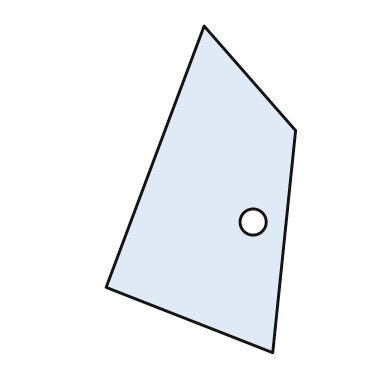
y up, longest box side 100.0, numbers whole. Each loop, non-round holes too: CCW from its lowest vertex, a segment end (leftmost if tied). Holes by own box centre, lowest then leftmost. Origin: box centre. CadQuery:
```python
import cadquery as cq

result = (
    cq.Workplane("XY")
    .moveTo(22.0, -50.0)
    .lineTo(29.0, 18.0)
    .lineTo(1.0, 50.0)
    .lineTo(-29.0, -30.0)
    .close()
    .moveTo(16.0, -10.0)
    .circle(4.0)
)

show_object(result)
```